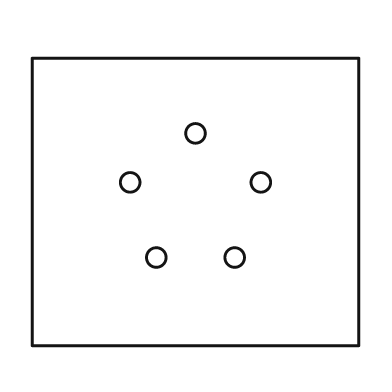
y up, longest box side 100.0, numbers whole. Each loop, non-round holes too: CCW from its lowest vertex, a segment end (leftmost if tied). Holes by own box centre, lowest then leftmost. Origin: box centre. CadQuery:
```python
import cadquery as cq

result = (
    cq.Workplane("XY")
    .moveTo(-50.0, -44.0)
    .lineTo(50.0, -44.0)
    .lineTo(50.0, 44.0)
    .lineTo(-50.0, 44.0)
    .close()
    .moveTo(-12.0, -17.0)
    .circle(3.0)
    .moveTo(12.0, -17.0)
    .circle(3.0)
    .moveTo(-20.0, 6.0)
    .circle(3.0)
    .moveTo(20.0, 6.0)
    .circle(3.0)
    .moveTo(0.0, 21.0)
    .circle(3.0)
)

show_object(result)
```